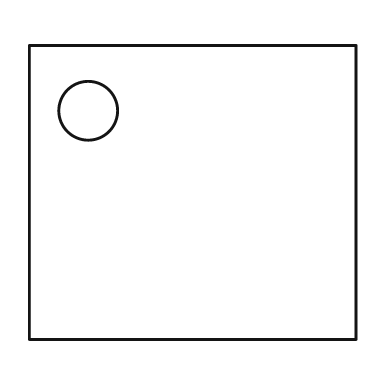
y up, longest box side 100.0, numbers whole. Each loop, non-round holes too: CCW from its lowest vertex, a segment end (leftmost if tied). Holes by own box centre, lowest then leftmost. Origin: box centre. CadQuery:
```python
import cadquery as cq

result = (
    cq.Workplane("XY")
    .moveTo(-50.0, -45.0)
    .lineTo(50.0, -45.0)
    .lineTo(50.0, 45.0)
    .lineTo(-50.0, 45.0)
    .close()
    .moveTo(-32.0, 25.0)
    .circle(9.0)
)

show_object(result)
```